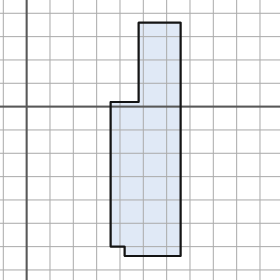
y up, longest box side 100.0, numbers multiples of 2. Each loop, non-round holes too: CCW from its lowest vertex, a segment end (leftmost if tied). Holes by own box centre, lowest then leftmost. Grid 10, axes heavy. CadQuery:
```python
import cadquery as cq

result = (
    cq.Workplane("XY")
    .moveTo(42.0, -64.0)
    .lineTo(66.0, -64.0)
    .lineTo(66.0, 36.0)
    .lineTo(48.0, 36.0)
    .lineTo(48.0, 2.0)
    .lineTo(36.0, 2.0)
    .lineTo(36.0, -60.0)
    .lineTo(42.0, -60.0)
    .close()
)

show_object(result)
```